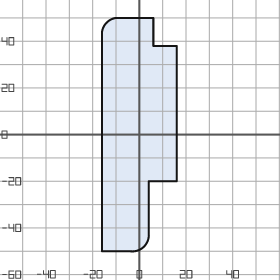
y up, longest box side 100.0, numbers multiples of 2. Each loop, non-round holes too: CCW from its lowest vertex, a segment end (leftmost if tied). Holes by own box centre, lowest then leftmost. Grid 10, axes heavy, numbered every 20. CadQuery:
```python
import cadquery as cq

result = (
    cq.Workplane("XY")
    .moveTo(-16.0, -50.0)
    .lineTo(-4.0, -50.0)
    .threePointArc((2.0, -48.0), (4.0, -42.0))
    .lineTo(4.0, -20.0)
    .lineTo(16.0, -20.0)
    .lineTo(16.0, 38.0)
    .lineTo(6.0, 38.0)
    .lineTo(6.0, 50.0)
    .lineTo(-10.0, 50.0)
    .threePointArc((-14.0, 48.0), (-16.0, 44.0))
    .close()
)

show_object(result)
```